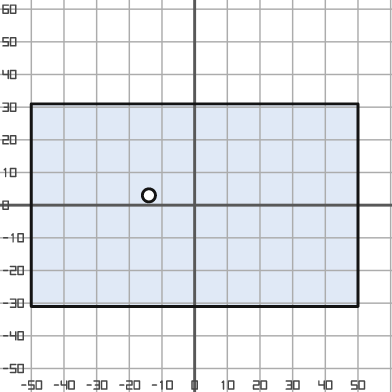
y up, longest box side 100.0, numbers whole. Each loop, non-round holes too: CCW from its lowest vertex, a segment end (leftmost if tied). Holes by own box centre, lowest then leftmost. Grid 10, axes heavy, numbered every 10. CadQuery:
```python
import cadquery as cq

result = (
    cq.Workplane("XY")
    .moveTo(-50.0, -31.0)
    .lineTo(50.0, -31.0)
    .lineTo(50.0, 31.0)
    .lineTo(-50.0, 31.0)
    .close()
    .moveTo(-14.0, 3.0)
    .circle(2.0)
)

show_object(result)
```